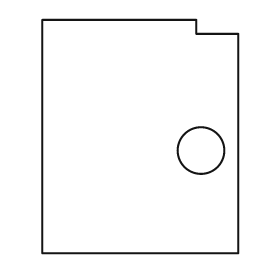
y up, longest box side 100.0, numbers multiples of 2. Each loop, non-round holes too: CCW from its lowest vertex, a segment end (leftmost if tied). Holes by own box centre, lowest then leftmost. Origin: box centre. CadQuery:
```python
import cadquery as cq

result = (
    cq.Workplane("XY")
    .moveTo(-42.0, -50.0)
    .lineTo(42.0, -50.0)
    .lineTo(42.0, 44.0)
    .lineTo(24.0, 44.0)
    .lineTo(24.0, 50.0)
    .lineTo(-42.0, 50.0)
    .close()
    .moveTo(26.0, -6.0)
    .circle(10.0)
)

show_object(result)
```